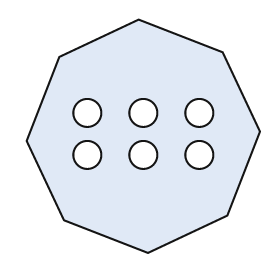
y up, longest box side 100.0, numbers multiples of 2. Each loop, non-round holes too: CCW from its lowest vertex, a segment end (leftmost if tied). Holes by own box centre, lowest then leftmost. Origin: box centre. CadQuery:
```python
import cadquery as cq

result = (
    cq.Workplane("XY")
    .moveTo(2.0, -50.0)
    .lineTo(36.0, -34.0)
    .lineTo(50.0, 2.0)
    .lineTo(34.0, 36.0)
    .lineTo(-2.0, 50.0)
    .lineTo(-36.0, 34.0)
    .lineTo(-50.0, -2.0)
    .lineTo(-34.0, -36.0)
    .close()
    .moveTo(-24.0, -8.0)
    .circle(6.0)
    .moveTo(0.0, -8.0)
    .circle(6.0)
    .moveTo(24.0, -8.0)
    .circle(6.0)
    .moveTo(-24.0, 10.0)
    .circle(6.0)
    .moveTo(0.0, 10.0)
    .circle(6.0)
    .moveTo(24.0, 10.0)
    .circle(6.0)
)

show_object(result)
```